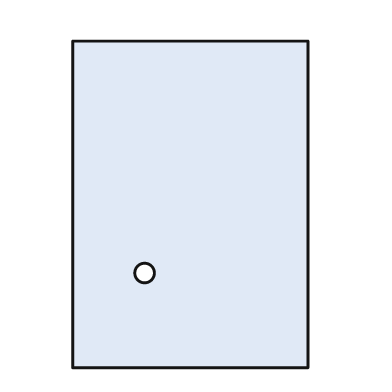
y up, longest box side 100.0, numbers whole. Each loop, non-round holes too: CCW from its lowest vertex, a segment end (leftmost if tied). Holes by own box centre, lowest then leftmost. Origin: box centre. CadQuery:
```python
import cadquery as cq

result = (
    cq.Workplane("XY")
    .moveTo(-36.0, -50.0)
    .lineTo(36.0, -50.0)
    .lineTo(36.0, 50.0)
    .lineTo(-36.0, 50.0)
    .close()
    .moveTo(-14.0, -21.0)
    .circle(3.0)
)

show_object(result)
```